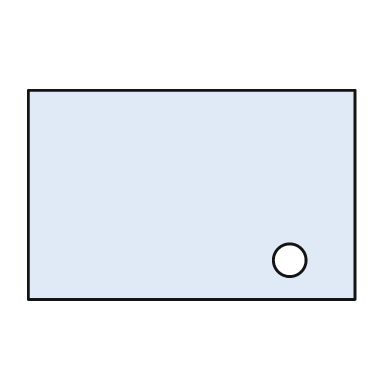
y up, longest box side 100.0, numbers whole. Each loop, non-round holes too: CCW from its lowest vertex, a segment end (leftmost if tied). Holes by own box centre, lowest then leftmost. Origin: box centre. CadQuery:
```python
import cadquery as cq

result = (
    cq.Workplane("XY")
    .moveTo(-50.0, -32.0)
    .lineTo(50.0, -32.0)
    .lineTo(50.0, 32.0)
    .lineTo(-50.0, 32.0)
    .close()
    .moveTo(30.0, -20.0)
    .circle(5.0)
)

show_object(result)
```